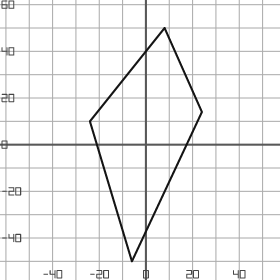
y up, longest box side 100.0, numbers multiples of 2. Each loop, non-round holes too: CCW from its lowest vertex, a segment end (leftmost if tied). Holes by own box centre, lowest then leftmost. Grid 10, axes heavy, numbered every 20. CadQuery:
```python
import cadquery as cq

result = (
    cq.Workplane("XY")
    .moveTo(-6.0, -50.0)
    .lineTo(24.0, 14.0)
    .lineTo(8.0, 50.0)
    .lineTo(-24.0, 10.0)
    .close()
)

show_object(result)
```